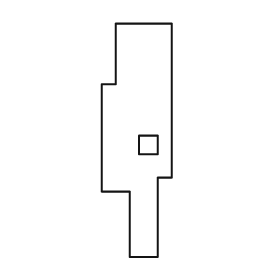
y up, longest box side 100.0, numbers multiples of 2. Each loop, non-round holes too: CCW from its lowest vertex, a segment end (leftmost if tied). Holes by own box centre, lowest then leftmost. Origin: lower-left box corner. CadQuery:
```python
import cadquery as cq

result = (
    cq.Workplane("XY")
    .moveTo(12.0, 0.0)
    .lineTo(24.0, 0.0)
    .lineTo(24.0, 34.0)
    .lineTo(30.0, 34.0)
    .lineTo(30.0, 100.0)
    .lineTo(6.0, 100.0)
    .lineTo(6.0, 74.0)
    .lineTo(0.0, 74.0)
    .lineTo(0.0, 28.0)
    .lineTo(12.0, 28.0)
    .close()
    .moveTo(16.0, 44.0)
    .lineTo(24.0, 44.0)
    .lineTo(24.0, 52.0)
    .lineTo(16.0, 52.0)
    .close()
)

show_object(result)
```